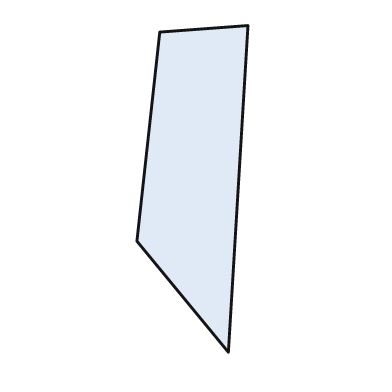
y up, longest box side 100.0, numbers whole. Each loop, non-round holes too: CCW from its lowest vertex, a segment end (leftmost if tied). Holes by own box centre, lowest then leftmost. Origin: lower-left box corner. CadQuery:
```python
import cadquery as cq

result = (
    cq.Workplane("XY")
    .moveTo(28.0, 0.0)
    .lineTo(34.0, 100.0)
    .lineTo(7.0, 98.0)
    .lineTo(0.0, 34.0)
    .close()
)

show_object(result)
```